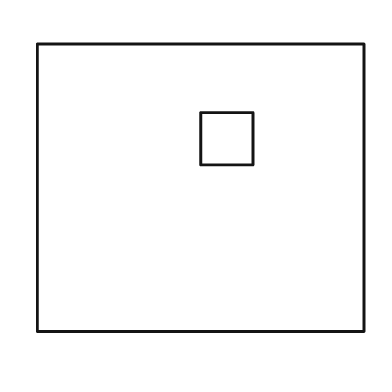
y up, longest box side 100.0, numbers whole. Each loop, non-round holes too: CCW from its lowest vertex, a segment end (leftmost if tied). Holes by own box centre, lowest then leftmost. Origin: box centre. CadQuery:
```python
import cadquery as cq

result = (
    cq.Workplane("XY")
    .moveTo(-50.0, -44.0)
    .lineTo(50.0, -44.0)
    .lineTo(50.0, 44.0)
    .lineTo(-50.0, 44.0)
    .close()
    .moveTo(0.0, 7.0)
    .lineTo(16.0, 7.0)
    .lineTo(16.0, 23.0)
    .lineTo(0.0, 23.0)
    .close()
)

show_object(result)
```